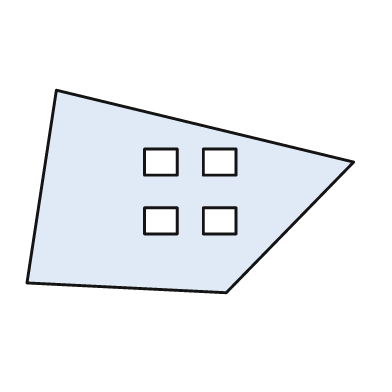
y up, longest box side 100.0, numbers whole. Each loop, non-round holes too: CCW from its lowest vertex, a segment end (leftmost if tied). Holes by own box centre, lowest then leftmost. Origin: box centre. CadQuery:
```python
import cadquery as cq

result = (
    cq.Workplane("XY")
    .moveTo(11.0, -31.0)
    .lineTo(50.0, 9.0)
    .lineTo(-41.0, 31.0)
    .lineTo(-50.0, -28.0)
    .close()
    .moveTo(-14.0, -13.0)
    .lineTo(-4.0, -13.0)
    .lineTo(-4.0, -5.0)
    .lineTo(-14.0, -5.0)
    .close()
    .moveTo(4.0, -13.0)
    .lineTo(14.0, -13.0)
    .lineTo(14.0, -5.0)
    .lineTo(4.0, -5.0)
    .close()
    .moveTo(-14.0, 5.0)
    .lineTo(-4.0, 5.0)
    .lineTo(-4.0, 13.0)
    .lineTo(-14.0, 13.0)
    .close()
    .moveTo(4.0, 5.0)
    .lineTo(14.0, 5.0)
    .lineTo(14.0, 13.0)
    .lineTo(4.0, 13.0)
    .close()
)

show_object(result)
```